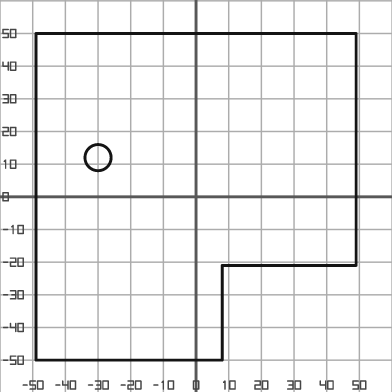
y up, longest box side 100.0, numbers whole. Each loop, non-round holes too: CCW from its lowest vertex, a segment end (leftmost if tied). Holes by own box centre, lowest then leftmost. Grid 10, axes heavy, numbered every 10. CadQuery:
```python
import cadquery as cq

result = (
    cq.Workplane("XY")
    .moveTo(-49.0, -50.0)
    .lineTo(8.0, -50.0)
    .lineTo(8.0, -21.0)
    .lineTo(49.0, -21.0)
    .lineTo(49.0, 50.0)
    .lineTo(-49.0, 50.0)
    .close()
    .moveTo(-30.0, 12.0)
    .circle(4.0)
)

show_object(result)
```